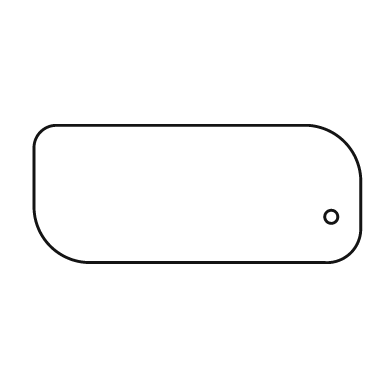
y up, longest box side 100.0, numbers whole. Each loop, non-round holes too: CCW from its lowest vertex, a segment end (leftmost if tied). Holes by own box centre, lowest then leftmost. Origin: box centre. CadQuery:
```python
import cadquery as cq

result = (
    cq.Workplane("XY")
    .moveTo(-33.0, -21.0)
    .lineTo(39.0, -21.0)
    .threePointArc((47.0, -18.0), (50.0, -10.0))
    .lineTo(50.0, 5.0)
    .threePointArc((45.0, 16.0), (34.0, 21.0))
    .lineTo(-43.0, 21.0)
    .threePointArc((-48.0, 19.0), (-50.0, 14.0))
    .lineTo(-50.0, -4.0)
    .threePointArc((-45.0, -16.0), (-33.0, -21.0))
    .close()
    .moveTo(41.0, -7.0)
    .circle(2.0)
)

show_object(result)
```